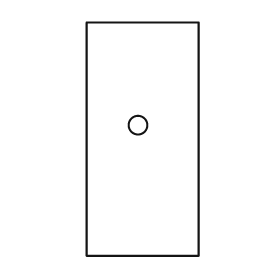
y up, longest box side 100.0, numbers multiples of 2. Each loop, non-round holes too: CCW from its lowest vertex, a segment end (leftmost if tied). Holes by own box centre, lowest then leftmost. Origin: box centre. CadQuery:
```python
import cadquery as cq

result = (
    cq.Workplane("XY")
    .moveTo(-24.0, -50.0)
    .lineTo(24.0, -50.0)
    .lineTo(24.0, 50.0)
    .lineTo(-24.0, 50.0)
    .close()
    .moveTo(-2.0, 6.0)
    .circle(4.0)
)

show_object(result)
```